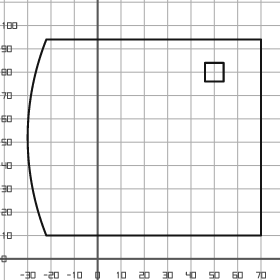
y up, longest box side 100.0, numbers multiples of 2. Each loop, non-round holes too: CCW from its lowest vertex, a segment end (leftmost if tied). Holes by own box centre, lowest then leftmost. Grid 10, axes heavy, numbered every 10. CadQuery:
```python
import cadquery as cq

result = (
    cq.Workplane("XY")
    .moveTo(-22.0, 10.0)
    .lineTo(70.0, 10.0)
    .lineTo(70.0, 94.0)
    .lineTo(-22.0, 94.0)
    .threePointArc((-30.0, 52.0), (-22.0, 10.0))
    .close()
    .moveTo(46.0, 76.0)
    .lineTo(54.0, 76.0)
    .lineTo(54.0, 84.0)
    .lineTo(46.0, 84.0)
    .close()
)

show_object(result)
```